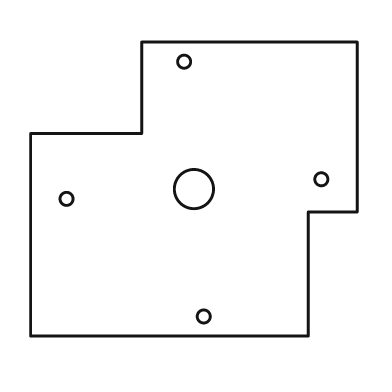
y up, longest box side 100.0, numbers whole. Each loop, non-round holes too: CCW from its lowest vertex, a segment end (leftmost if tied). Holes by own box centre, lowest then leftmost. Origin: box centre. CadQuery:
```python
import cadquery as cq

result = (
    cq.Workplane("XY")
    .moveTo(-50.0, -45.0)
    .lineTo(35.0, -45.0)
    .lineTo(35.0, -7.0)
    .lineTo(50.0, -7.0)
    .lineTo(50.0, 45.0)
    .lineTo(-16.0, 45.0)
    .lineTo(-16.0, 17.0)
    .lineTo(-50.0, 17.0)
    .close()
    .moveTo(3.0, -39.0)
    .circle(2.0)
    .moveTo(-39.0, -3.0)
    .circle(2.0)
    .moveTo(0.0, 0.0)
    .circle(6.0)
    .moveTo(39.0, 3.0)
    .circle(2.0)
    .moveTo(-3.0, 39.0)
    .circle(2.0)
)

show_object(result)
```